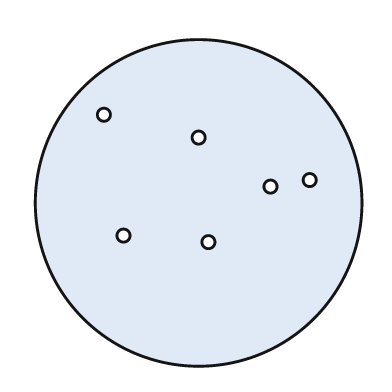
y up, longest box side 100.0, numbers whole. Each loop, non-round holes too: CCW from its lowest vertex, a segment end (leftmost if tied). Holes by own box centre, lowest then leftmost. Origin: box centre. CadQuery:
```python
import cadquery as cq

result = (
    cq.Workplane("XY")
    .moveTo(0.0, 0.0)
    .circle(50.0)
    .moveTo(3.0, -12.0)
    .circle(2.0)
    .moveTo(-23.0, -10.0)
    .circle(2.0)
    .moveTo(22.0, 5.0)
    .circle(2.0)
    .moveTo(34.0, 7.0)
    .circle(2.0)
    .moveTo(0.0, 20.0)
    .circle(2.0)
    .moveTo(-29.0, 27.0)
    .circle(2.0)
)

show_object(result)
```